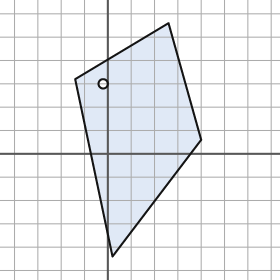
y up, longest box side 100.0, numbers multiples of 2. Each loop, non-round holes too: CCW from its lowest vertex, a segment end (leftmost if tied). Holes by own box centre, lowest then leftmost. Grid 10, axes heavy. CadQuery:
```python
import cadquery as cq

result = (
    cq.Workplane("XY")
    .moveTo(2.0, -44.0)
    .lineTo(40.0, 6.0)
    .lineTo(26.0, 56.0)
    .lineTo(-14.0, 32.0)
    .close()
    .moveTo(-2.0, 30.0)
    .circle(2.0)
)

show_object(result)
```